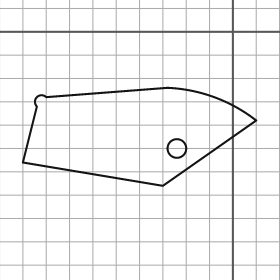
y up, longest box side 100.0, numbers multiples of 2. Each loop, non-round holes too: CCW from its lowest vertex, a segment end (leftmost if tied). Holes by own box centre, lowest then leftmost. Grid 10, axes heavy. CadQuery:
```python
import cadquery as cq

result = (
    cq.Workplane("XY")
    .moveTo(-30.0, -66.0)
    .lineTo(10.0, -38.0)
    .threePointArc((-8.0, -28.0), (-28.0, -24.0))
    .lineTo(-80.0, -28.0)
    .threePointArc((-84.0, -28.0), (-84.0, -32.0))
    .lineTo(-90.0, -56.0)
    .close()
    .moveTo(-24.0, -50.0)
    .circle(4.0)
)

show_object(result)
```